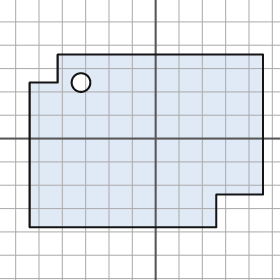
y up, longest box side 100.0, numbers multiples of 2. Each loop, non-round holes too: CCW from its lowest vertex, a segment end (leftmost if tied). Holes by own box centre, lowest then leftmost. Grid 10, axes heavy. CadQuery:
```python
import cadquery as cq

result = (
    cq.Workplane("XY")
    .moveTo(-54.0, -38.0)
    .lineTo(26.0, -38.0)
    .lineTo(26.0, -24.0)
    .lineTo(46.0, -24.0)
    .lineTo(46.0, 36.0)
    .lineTo(-42.0, 36.0)
    .lineTo(-42.0, 24.0)
    .lineTo(-54.0, 24.0)
    .close()
    .moveTo(-32.0, 24.0)
    .circle(4.0)
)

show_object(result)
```